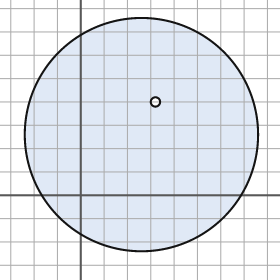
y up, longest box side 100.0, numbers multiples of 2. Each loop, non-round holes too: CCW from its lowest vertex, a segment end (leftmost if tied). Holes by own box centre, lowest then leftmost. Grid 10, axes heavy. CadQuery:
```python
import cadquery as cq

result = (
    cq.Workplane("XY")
    .moveTo(26.0, 26.0)
    .circle(50.0)
    .moveTo(32.0, 40.0)
    .circle(2.0)
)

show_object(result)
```